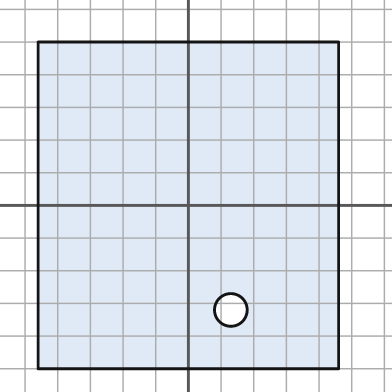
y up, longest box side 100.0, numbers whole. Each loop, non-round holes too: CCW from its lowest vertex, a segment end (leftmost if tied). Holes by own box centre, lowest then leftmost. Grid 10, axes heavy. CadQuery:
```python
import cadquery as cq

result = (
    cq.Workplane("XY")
    .moveTo(-46.0, -50.0)
    .lineTo(46.0, -50.0)
    .lineTo(46.0, 50.0)
    .lineTo(-46.0, 50.0)
    .close()
    .moveTo(13.0, -32.0)
    .circle(5.0)
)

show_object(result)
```